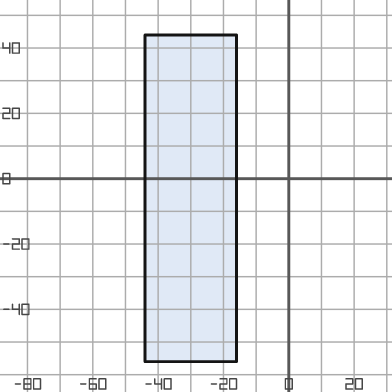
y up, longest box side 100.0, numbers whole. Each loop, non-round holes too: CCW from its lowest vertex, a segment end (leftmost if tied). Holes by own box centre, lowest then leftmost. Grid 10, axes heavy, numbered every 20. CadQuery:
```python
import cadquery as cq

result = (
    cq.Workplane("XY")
    .moveTo(-44.0, -56.0)
    .lineTo(-16.0, -56.0)
    .lineTo(-16.0, 44.0)
    .lineTo(-44.0, 44.0)
    .close()
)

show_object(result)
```